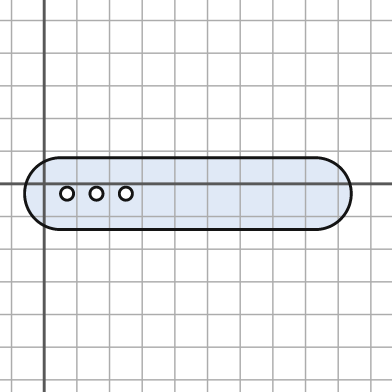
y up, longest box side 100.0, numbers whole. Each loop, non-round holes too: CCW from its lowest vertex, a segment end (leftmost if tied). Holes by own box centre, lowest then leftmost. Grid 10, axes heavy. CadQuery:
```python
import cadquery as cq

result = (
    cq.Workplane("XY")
    .moveTo(5.0, -14.0)
    .lineTo(83.0, -14.0)
    .threePointArc((94.0, -3.0), (83.0, 8.0))
    .lineTo(5.0, 8.0)
    .threePointArc((-6.0, -3.0), (5.0, -14.0))
    .close()
    .moveTo(7.0, -3.0)
    .circle(2.0)
    .moveTo(16.0, -3.0)
    .circle(2.0)
    .moveTo(25.0, -3.0)
    .circle(2.0)
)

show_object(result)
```